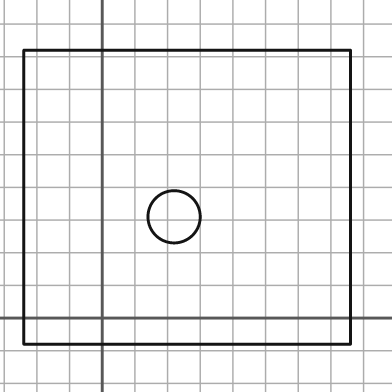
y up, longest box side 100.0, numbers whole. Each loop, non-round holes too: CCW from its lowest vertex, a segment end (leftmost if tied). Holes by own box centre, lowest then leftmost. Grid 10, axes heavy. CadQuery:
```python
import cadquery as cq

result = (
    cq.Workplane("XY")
    .moveTo(-24.0, -8.0)
    .lineTo(76.0, -8.0)
    .lineTo(76.0, 82.0)
    .lineTo(-24.0, 82.0)
    .close()
    .moveTo(22.0, 31.0)
    .circle(8.0)
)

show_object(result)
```